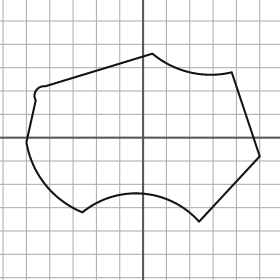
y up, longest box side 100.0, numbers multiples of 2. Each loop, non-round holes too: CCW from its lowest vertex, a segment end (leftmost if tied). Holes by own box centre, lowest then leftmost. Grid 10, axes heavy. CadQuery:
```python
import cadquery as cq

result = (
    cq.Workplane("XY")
    .moveTo(24.0, -36.0)
    .lineTo(50.0, -8.0)
    .lineTo(38.0, 28.0)
    .threePointArc((20.0, 28.0), (4.0, 36.0))
    .lineTo(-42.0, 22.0)
    .threePointArc((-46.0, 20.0), (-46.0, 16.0))
    .lineTo(-50.0, -2.0)
    .threePointArc((-42.0, -20.0), (-26.0, -32.0))
    .threePointArc((0.0, -24.0), (24.0, -36.0))
    .close()
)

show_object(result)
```